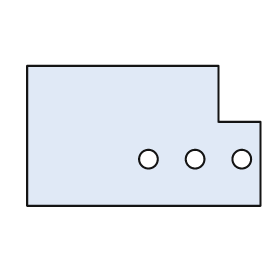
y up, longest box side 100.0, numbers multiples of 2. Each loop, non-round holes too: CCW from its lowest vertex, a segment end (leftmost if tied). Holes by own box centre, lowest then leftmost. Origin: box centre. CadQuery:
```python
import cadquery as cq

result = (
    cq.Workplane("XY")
    .moveTo(-50.0, -30.0)
    .lineTo(50.0, -30.0)
    .lineTo(50.0, 6.0)
    .lineTo(32.0, 6.0)
    .lineTo(32.0, 30.0)
    .lineTo(-50.0, 30.0)
    .close()
    .moveTo(2.0, -10.0)
    .circle(4.0)
    .moveTo(22.0, -10.0)
    .circle(4.0)
    .moveTo(42.0, -10.0)
    .circle(4.0)
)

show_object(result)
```